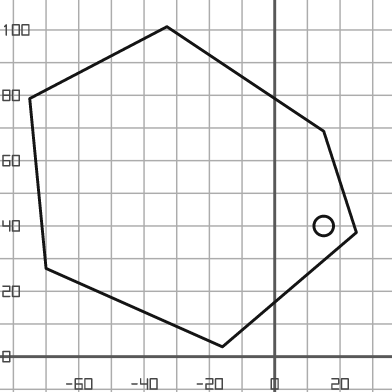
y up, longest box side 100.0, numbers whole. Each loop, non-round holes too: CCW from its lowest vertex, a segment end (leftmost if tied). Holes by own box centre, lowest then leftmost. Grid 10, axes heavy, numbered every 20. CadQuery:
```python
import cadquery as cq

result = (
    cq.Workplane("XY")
    .moveTo(-16.0, 3.0)
    .lineTo(25.0, 38.0)
    .lineTo(15.0, 69.0)
    .lineTo(-33.0, 101.0)
    .lineTo(-75.0, 79.0)
    .lineTo(-70.0, 27.0)
    .close()
    .moveTo(15.0, 40.0)
    .circle(3.0)
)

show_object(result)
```